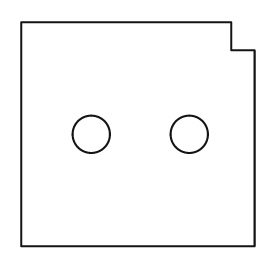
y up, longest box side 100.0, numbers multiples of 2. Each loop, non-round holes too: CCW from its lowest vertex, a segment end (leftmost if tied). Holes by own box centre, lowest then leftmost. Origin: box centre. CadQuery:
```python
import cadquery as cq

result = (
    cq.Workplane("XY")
    .moveTo(-50.0, -48.0)
    .lineTo(50.0, -48.0)
    .lineTo(50.0, 36.0)
    .lineTo(40.0, 36.0)
    .lineTo(40.0, 48.0)
    .lineTo(-50.0, 48.0)
    .close()
    .moveTo(-20.0, 0.0)
    .circle(8.0)
    .moveTo(22.0, 0.0)
    .circle(8.0)
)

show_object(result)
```